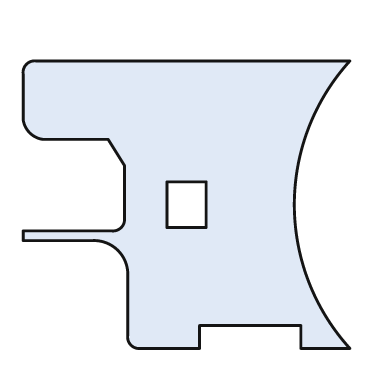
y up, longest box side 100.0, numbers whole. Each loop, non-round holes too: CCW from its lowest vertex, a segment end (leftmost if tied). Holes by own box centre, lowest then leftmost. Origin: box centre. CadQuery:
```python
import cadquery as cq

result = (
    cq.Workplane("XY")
    .moveTo(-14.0, -44.0)
    .lineTo(4.0, -44.0)
    .lineTo(4.0, -37.0)
    .lineTo(35.0, -37.0)
    .lineTo(35.0, -44.0)
    .lineTo(50.0, -44.0)
    .threePointArc((33.0, 0.0), (50.0, 44.0))
    .lineTo(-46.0, 44.0)
    .threePointArc((-49.0, 43.0), (-50.0, 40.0))
    .lineTo(-50.0, 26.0)
    .threePointArc((-48.0, 22.0), (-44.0, 20.0))
    .lineTo(-24.0, 20.0)
    .lineTo(-19.0, 12.0)
    .lineTo(-19.0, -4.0)
    .threePointArc((-20.0, -7.0), (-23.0, -8.0))
    .lineTo(-50.0, -8.0)
    .lineTo(-50.0, -11.0)
    .lineTo(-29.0, -11.0)
    .threePointArc((-21.0, -14.0), (-18.0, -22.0))
    .lineTo(-18.0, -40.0)
    .threePointArc((-17.0, -43.0), (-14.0, -44.0))
    .close()
    .moveTo(-6.0, -7.0)
    .lineTo(6.0, -7.0)
    .lineTo(6.0, 7.0)
    .lineTo(-6.0, 7.0)
    .close()
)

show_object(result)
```